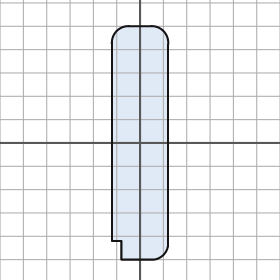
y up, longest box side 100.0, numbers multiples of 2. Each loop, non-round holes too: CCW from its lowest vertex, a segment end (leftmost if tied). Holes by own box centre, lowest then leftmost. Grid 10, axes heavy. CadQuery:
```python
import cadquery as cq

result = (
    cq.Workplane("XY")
    .moveTo(-8.0, -50.0)
    .lineTo(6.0, -50.0)
    .threePointArc((10.0, -48.0), (12.0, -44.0))
    .lineTo(12.0, 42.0)
    .threePointArc((10.0, 48.0), (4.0, 50.0))
    .lineTo(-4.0, 50.0)
    .threePointArc((-10.0, 48.0), (-12.0, 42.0))
    .lineTo(-12.0, -42.0)
    .lineTo(-8.0, -42.0)
    .close()
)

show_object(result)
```